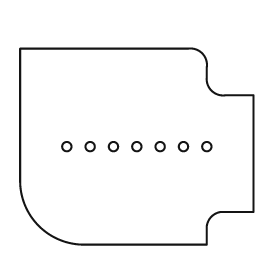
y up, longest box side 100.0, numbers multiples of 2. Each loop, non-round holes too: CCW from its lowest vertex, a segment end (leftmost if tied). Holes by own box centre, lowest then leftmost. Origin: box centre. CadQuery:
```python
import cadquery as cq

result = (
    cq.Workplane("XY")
    .moveTo(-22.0, -42.0)
    .lineTo(30.0, -42.0)
    .lineTo(30.0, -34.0)
    .threePointArc((32.0, -30.0), (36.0, -28.0))
    .lineTo(50.0, -28.0)
    .lineTo(50.0, 22.0)
    .lineTo(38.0, 22.0)
    .threePointArc((32.0, 24.0), (30.0, 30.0))
    .lineTo(30.0, 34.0)
    .threePointArc((28.0, 40.0), (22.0, 42.0))
    .lineTo(-50.0, 42.0)
    .lineTo(-50.0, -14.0)
    .threePointArc((-42.0, -34.0), (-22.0, -42.0))
    .close()
    .moveTo(-30.0, 0.0)
    .circle(2.0)
    .moveTo(-20.0, 0.0)
    .circle(2.0)
    .moveTo(-10.0, 0.0)
    .circle(2.0)
    .moveTo(0.0, 0.0)
    .circle(2.0)
    .moveTo(10.0, 0.0)
    .circle(2.0)
    .moveTo(20.0, 0.0)
    .circle(2.0)
    .moveTo(30.0, 0.0)
    .circle(2.0)
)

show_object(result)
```